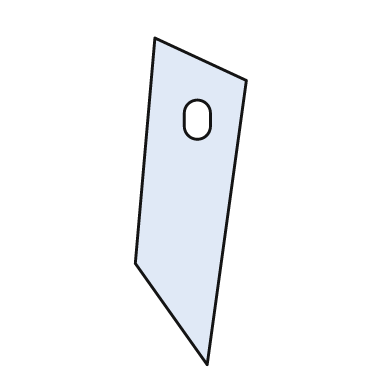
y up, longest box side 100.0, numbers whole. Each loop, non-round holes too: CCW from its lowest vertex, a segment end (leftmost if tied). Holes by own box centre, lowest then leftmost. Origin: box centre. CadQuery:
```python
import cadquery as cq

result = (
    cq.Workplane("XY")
    .moveTo(5.0, -50.0)
    .lineTo(17.0, 37.0)
    .lineTo(-11.0, 50.0)
    .lineTo(-17.0, -19.0)
    .close()
    .moveTo(-2.0, 23.0)
    .threePointArc((2.0, 19.0), (6.0, 23.0))
    .lineTo(6.0, 27.0)
    .threePointArc((2.0, 31.0), (-2.0, 27.0))
    .close()
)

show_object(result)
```